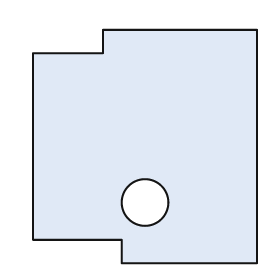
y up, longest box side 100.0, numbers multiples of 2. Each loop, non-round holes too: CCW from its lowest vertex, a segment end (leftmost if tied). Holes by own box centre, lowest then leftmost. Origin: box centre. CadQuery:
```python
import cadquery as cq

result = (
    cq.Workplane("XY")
    .moveTo(-10.0, -50.0)
    .lineTo(48.0, -50.0)
    .lineTo(48.0, 50.0)
    .lineTo(-18.0, 50.0)
    .lineTo(-18.0, 40.0)
    .lineTo(-48.0, 40.0)
    .lineTo(-48.0, -40.0)
    .lineTo(-10.0, -40.0)
    .close()
    .moveTo(0.0, -24.0)
    .circle(10.0)
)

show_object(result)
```